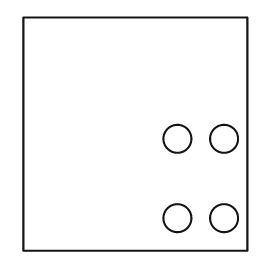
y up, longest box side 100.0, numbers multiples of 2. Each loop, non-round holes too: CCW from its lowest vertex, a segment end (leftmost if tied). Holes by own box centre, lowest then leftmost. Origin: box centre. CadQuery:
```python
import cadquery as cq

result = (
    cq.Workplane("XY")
    .moveTo(-48.0, -50.0)
    .lineTo(48.0, -50.0)
    .lineTo(48.0, 50.0)
    .lineTo(-48.0, 50.0)
    .close()
    .moveTo(18.0, -36.0)
    .circle(6.0)
    .moveTo(38.0, -36.0)
    .circle(6.0)
    .moveTo(18.0, -2.0)
    .circle(6.0)
    .moveTo(38.0, -2.0)
    .circle(6.0)
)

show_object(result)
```